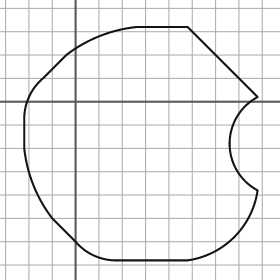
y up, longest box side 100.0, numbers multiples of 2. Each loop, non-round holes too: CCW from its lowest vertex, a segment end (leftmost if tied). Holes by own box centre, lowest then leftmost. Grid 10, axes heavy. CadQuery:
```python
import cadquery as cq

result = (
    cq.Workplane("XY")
    .moveTo(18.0, -68.0)
    .lineTo(48.0, -68.0)
    .threePointArc((68.0, -58.0), (78.0, -38.0))
    .threePointArc((66.0, -18.0), (78.0, 2.0))
    .lineTo(48.0, 32.0)
    .lineTo(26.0, 32.0)
    .threePointArc((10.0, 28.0), (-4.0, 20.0))
    .lineTo(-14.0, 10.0)
    .threePointArc((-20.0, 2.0), (-22.0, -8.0))
    .lineTo(-22.0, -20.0)
    .threePointArc((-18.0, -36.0), (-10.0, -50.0))
    .lineTo(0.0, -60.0)
    .threePointArc((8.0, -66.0), (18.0, -68.0))
    .close()
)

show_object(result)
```